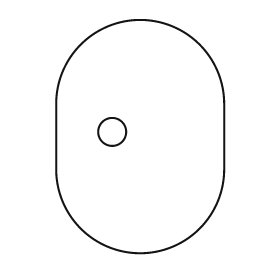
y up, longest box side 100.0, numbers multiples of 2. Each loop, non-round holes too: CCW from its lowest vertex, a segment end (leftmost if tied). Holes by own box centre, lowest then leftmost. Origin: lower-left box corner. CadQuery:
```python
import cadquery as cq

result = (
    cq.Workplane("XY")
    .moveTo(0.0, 36.0)
    .threePointArc((36.0, 0.0), (72.0, 36.0))
    .lineTo(72.0, 64.0)
    .threePointArc((36.0, 100.0), (0.0, 64.0))
    .close()
    .moveTo(24.0, 52.0)
    .circle(6.0)
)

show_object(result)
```